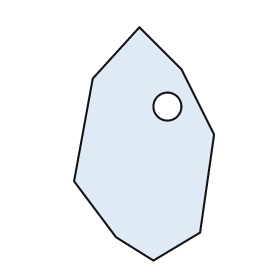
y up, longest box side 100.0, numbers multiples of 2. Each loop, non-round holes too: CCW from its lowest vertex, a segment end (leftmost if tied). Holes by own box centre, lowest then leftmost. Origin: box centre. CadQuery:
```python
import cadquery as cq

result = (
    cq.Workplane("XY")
    .moveTo(4.0, -50.0)
    .lineTo(24.0, -38.0)
    .lineTo(30.0, 4.0)
    .lineTo(16.0, 32.0)
    .lineTo(-2.0, 50.0)
    .lineTo(-22.0, 28.0)
    .lineTo(-30.0, -16.0)
    .lineTo(-12.0, -40.0)
    .close()
    .moveTo(10.0, 16.0)
    .circle(6.0)
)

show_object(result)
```